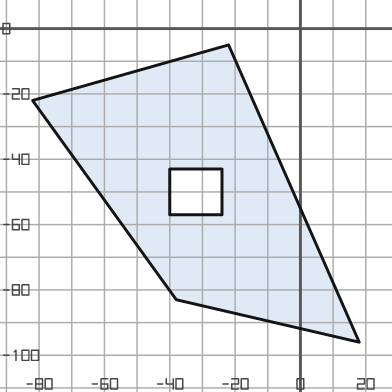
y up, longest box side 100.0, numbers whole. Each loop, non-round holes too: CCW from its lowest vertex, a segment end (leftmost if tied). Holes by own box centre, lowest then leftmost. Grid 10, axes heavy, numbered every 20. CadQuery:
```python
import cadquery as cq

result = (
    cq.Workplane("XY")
    .moveTo(18.0, -96.0)
    .lineTo(-22.0, -5.0)
    .lineTo(-82.0, -22.0)
    .lineTo(-38.0, -83.0)
    .close()
    .moveTo(-40.0, -57.0)
    .lineTo(-24.0, -57.0)
    .lineTo(-24.0, -43.0)
    .lineTo(-40.0, -43.0)
    .close()
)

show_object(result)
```